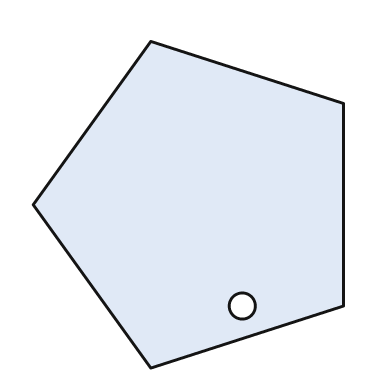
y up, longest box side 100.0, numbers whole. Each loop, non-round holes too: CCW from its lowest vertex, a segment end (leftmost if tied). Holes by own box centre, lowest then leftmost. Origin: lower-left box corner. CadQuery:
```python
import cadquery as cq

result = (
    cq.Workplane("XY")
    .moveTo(36.0, 0.0)
    .lineTo(95.0, 19.0)
    .lineTo(95.0, 81.0)
    .lineTo(36.0, 100.0)
    .lineTo(0.0, 50.0)
    .close()
    .moveTo(64.0, 19.0)
    .circle(4.0)
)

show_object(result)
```